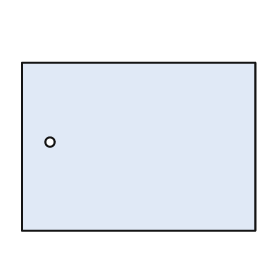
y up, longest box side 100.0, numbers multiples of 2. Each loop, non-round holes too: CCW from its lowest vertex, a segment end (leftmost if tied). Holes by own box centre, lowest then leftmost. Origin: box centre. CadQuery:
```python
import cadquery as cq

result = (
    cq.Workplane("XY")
    .moveTo(-50.0, -36.0)
    .lineTo(50.0, -36.0)
    .lineTo(50.0, 36.0)
    .lineTo(-50.0, 36.0)
    .close()
    .moveTo(-38.0, 2.0)
    .circle(2.0)
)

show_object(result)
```